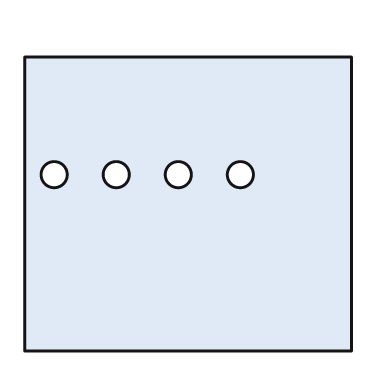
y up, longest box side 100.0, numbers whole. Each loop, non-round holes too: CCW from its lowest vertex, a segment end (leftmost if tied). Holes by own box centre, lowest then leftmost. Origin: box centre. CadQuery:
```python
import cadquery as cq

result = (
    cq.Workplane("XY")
    .moveTo(-50.0, -45.0)
    .lineTo(50.0, -45.0)
    .lineTo(50.0, 45.0)
    .lineTo(-50.0, 45.0)
    .close()
    .moveTo(-41.0, 9.0)
    .circle(4.0)
    .moveTo(-22.0, 9.0)
    .circle(4.0)
    .moveTo(-3.0, 9.0)
    .circle(4.0)
    .moveTo(16.0, 9.0)
    .circle(4.0)
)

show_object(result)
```